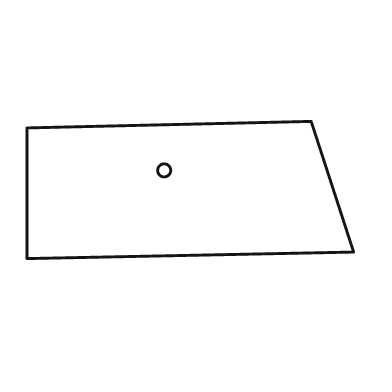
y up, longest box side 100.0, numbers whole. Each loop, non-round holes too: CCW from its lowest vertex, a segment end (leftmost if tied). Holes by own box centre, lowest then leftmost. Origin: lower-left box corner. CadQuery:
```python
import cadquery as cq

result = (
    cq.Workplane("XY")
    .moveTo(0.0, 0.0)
    .lineTo(100.0, 2.0)
    .lineTo(87.0, 42.0)
    .lineTo(0.0, 40.0)
    .close()
    .moveTo(42.0, 27.0)
    .circle(2.0)
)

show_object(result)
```